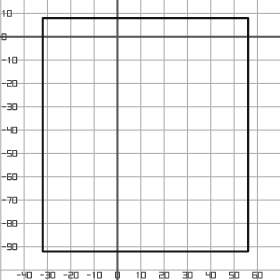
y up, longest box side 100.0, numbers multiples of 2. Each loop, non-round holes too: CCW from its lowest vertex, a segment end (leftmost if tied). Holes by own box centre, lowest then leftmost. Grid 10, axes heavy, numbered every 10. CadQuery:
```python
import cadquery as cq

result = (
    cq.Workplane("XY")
    .moveTo(-32.0, -92.0)
    .lineTo(56.0, -92.0)
    .lineTo(56.0, 8.0)
    .lineTo(-32.0, 8.0)
    .close()
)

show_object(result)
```